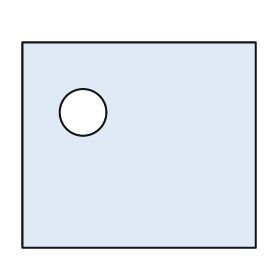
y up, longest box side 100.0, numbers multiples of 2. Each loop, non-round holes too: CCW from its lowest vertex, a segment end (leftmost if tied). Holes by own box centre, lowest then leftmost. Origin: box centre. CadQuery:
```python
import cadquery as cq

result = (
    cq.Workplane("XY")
    .moveTo(-50.0, -44.0)
    .lineTo(50.0, -44.0)
    .lineTo(50.0, 44.0)
    .lineTo(-50.0, 44.0)
    .close()
    .moveTo(-24.0, 14.0)
    .circle(10.0)
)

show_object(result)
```